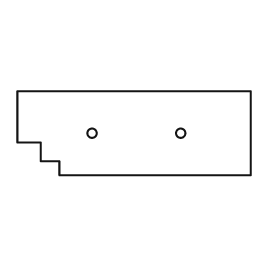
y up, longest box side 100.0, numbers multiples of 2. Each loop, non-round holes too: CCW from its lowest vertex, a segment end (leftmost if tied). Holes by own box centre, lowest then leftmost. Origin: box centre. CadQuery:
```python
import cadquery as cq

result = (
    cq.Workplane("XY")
    .moveTo(-32.0, -18.0)
    .lineTo(50.0, -18.0)
    .lineTo(50.0, 18.0)
    .lineTo(-50.0, 18.0)
    .lineTo(-50.0, -4.0)
    .lineTo(-40.0, -4.0)
    .lineTo(-40.0, -12.0)
    .lineTo(-32.0, -12.0)
    .close()
    .moveTo(-18.0, 0.0)
    .circle(2.0)
    .moveTo(20.0, 0.0)
    .circle(2.0)
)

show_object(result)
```